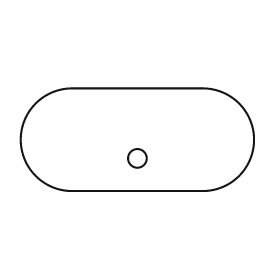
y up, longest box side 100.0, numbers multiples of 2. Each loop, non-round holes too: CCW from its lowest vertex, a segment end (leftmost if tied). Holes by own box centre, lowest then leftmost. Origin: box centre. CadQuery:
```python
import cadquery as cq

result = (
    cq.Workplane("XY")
    .moveTo(-28.0, -22.0)
    .lineTo(28.0, -22.0)
    .threePointArc((50.0, 0.0), (28.0, 22.0))
    .lineTo(-28.0, 22.0)
    .threePointArc((-50.0, 0.0), (-28.0, -22.0))
    .close()
    .moveTo(0.0, -8.0)
    .circle(4.0)
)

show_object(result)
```